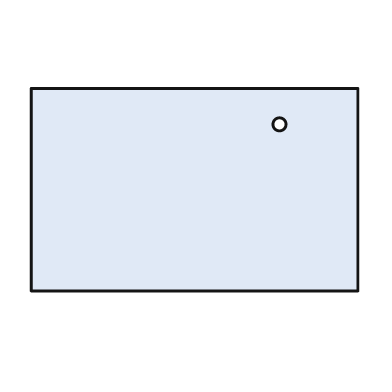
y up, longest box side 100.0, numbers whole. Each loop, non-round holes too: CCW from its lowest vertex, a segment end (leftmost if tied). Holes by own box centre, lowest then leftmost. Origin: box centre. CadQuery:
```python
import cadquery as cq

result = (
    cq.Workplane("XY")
    .moveTo(-50.0, -31.0)
    .lineTo(50.0, -31.0)
    .lineTo(50.0, 31.0)
    .lineTo(-50.0, 31.0)
    .close()
    .moveTo(26.0, 20.0)
    .circle(2.0)
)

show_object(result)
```